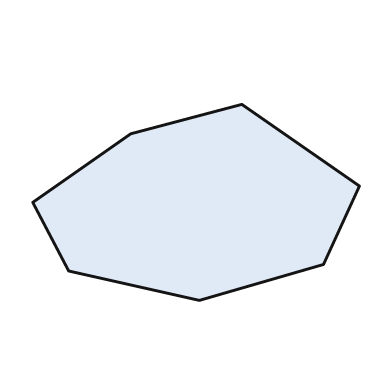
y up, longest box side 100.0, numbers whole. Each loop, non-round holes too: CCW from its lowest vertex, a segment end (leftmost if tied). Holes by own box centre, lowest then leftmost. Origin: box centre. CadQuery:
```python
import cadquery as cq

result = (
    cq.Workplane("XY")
    .moveTo(1.0, -30.0)
    .lineTo(39.0, -19.0)
    .lineTo(50.0, 5.0)
    .lineTo(14.0, 30.0)
    .lineTo(-20.0, 21.0)
    .lineTo(-50.0, 0.0)
    .lineTo(-39.0, -21.0)
    .close()
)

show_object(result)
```